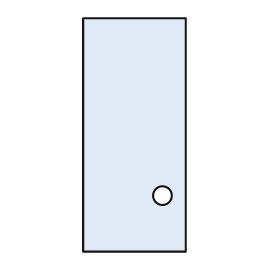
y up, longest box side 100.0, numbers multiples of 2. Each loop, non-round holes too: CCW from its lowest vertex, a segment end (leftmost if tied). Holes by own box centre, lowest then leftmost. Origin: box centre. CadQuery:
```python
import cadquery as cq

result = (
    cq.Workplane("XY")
    .moveTo(-22.0, -50.0)
    .lineTo(22.0, -50.0)
    .lineTo(22.0, 50.0)
    .lineTo(-22.0, 50.0)
    .close()
    .moveTo(12.0, -26.0)
    .circle(4.0)
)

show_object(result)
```